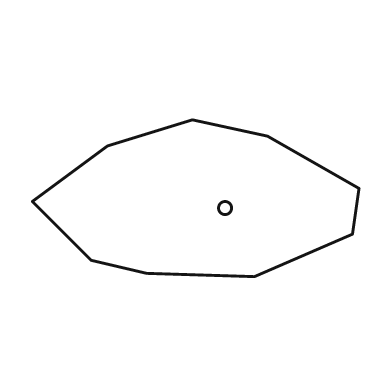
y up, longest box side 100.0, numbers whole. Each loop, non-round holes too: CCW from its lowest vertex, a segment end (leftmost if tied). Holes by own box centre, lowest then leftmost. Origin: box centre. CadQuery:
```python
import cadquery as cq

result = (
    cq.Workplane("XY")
    .moveTo(18.0, -24.0)
    .lineTo(48.0, -11.0)
    .lineTo(50.0, 3.0)
    .lineTo(22.0, 19.0)
    .lineTo(-1.0, 24.0)
    .lineTo(-27.0, 16.0)
    .lineTo(-50.0, -1.0)
    .lineTo(-32.0, -19.0)
    .lineTo(-15.0, -23.0)
    .close()
    .moveTo(9.0, -3.0)
    .circle(2.0)
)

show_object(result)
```